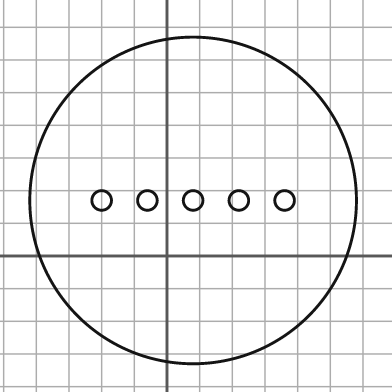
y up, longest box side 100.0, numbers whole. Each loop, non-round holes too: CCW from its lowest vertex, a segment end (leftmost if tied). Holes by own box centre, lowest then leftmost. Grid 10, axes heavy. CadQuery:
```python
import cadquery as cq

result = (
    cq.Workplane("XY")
    .moveTo(8.0, 17.0)
    .circle(50.0)
    .moveTo(-20.0, 17.0)
    .circle(3.0)
    .moveTo(-6.0, 17.0)
    .circle(3.0)
    .moveTo(8.0, 17.0)
    .circle(3.0)
    .moveTo(22.0, 17.0)
    .circle(3.0)
    .moveTo(36.0, 17.0)
    .circle(3.0)
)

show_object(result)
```